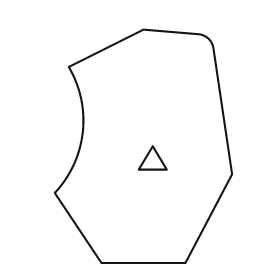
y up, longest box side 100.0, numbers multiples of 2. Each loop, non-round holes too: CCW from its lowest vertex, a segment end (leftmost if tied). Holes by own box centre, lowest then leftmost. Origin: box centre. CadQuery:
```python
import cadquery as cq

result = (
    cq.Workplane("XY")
    .moveTo(-18.0, -50.0)
    .lineTo(18.0, -50.0)
    .lineTo(38.0, -12.0)
    .lineTo(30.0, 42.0)
    .threePointArc((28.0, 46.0), (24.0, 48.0))
    .lineTo(0.0, 50.0)
    .lineTo(-32.0, 34.0)
    .threePointArc((-26.0, 6.0), (-38.0, -20.0))
    .close()
    .moveTo(-2.0, -10.0)
    .lineTo(10.0, -10.0)
    .lineTo(4.0, 0.0)
    .close()
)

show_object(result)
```